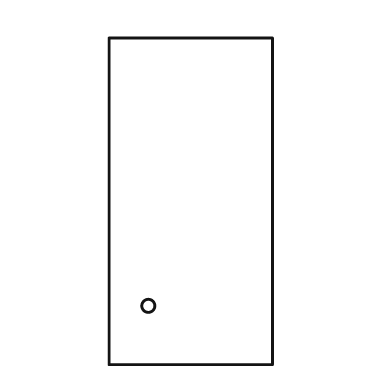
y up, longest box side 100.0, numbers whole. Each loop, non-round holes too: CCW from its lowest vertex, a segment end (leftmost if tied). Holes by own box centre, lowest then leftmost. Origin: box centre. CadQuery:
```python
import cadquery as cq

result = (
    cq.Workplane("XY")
    .moveTo(-25.0, -50.0)
    .lineTo(25.0, -50.0)
    .lineTo(25.0, 50.0)
    .lineTo(-25.0, 50.0)
    .close()
    .moveTo(-13.0, -32.0)
    .circle(2.0)
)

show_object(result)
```